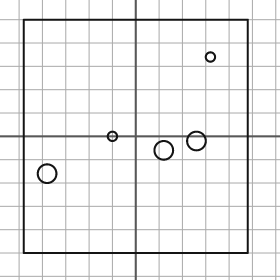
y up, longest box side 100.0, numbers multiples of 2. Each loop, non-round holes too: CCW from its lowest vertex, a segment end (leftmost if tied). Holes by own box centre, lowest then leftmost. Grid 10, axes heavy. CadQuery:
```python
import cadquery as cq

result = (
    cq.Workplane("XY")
    .moveTo(-48.0, -50.0)
    .lineTo(48.0, -50.0)
    .lineTo(48.0, 50.0)
    .lineTo(-48.0, 50.0)
    .close()
    .moveTo(-38.0, -16.0)
    .circle(4.0)
    .moveTo(12.0, -6.0)
    .circle(4.0)
    .moveTo(26.0, -2.0)
    .circle(4.0)
    .moveTo(-10.0, 0.0)
    .circle(2.0)
    .moveTo(32.0, 34.0)
    .circle(2.0)
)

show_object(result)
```